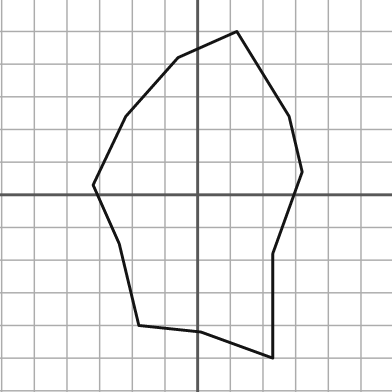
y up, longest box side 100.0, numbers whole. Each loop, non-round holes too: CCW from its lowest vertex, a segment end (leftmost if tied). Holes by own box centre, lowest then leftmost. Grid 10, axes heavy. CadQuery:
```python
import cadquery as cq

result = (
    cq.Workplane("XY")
    .moveTo(23.0, -50.0)
    .lineTo(23.0, -18.0)
    .lineTo(32.0, 7.0)
    .lineTo(28.0, 24.0)
    .lineTo(12.0, 50.0)
    .lineTo(-6.0, 42.0)
    .lineTo(-22.0, 24.0)
    .lineTo(-32.0, 3.0)
    .lineTo(-24.0, -15.0)
    .lineTo(-18.0, -40.0)
    .lineTo(1.0, -42.0)
    .close()
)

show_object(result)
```